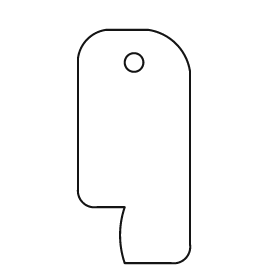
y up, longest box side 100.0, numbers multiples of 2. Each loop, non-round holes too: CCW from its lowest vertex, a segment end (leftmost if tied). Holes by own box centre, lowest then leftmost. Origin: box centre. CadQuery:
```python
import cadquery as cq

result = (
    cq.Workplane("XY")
    .moveTo(-4.0, -50.0)
    .lineTo(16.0, -50.0)
    .threePointArc((22.0, -48.0), (24.0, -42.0))
    .lineTo(24.0, 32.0)
    .threePointArc((18.0, 44.0), (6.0, 50.0))
    .lineTo(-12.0, 50.0)
    .threePointArc((-20.0, 46.0), (-24.0, 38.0))
    .lineTo(-24.0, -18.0)
    .threePointArc((-22.0, -24.0), (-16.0, -26.0))
    .lineTo(-4.0, -26.0)
    .threePointArc((-6.0, -38.0), (-4.0, -50.0))
    .close()
    .moveTo(0.0, 36.0)
    .circle(4.0)
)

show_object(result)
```